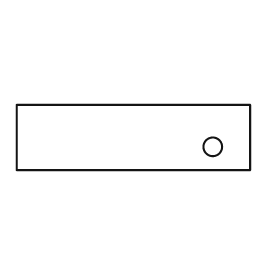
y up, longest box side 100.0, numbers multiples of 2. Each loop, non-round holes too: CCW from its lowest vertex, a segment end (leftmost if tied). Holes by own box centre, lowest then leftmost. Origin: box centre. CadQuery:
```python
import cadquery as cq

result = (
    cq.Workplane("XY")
    .moveTo(-50.0, -14.0)
    .lineTo(50.0, -14.0)
    .lineTo(50.0, 14.0)
    .lineTo(-50.0, 14.0)
    .close()
    .moveTo(34.0, -4.0)
    .circle(4.0)
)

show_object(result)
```